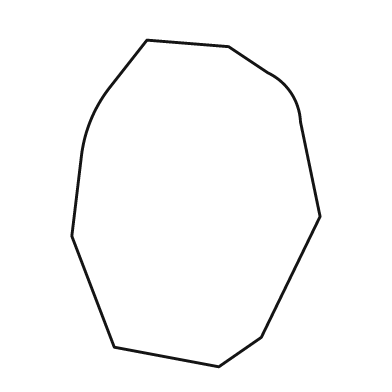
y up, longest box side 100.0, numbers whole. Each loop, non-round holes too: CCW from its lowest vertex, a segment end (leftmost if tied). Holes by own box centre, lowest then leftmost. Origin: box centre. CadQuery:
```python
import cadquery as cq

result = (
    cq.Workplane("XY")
    .moveTo(7.0, -50.0)
    .lineTo(20.0, -41.0)
    .lineTo(38.0, -4.0)
    .lineTo(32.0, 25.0)
    .threePointArc((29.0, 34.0), (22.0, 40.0))
    .lineTo(10.0, 48.0)
    .lineTo(-15.0, 50.0)
    .lineTo(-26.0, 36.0)
    .threePointArc((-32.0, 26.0), (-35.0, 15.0))
    .lineTo(-38.0, -10.0)
    .lineTo(-25.0, -44.0)
    .close()
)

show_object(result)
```